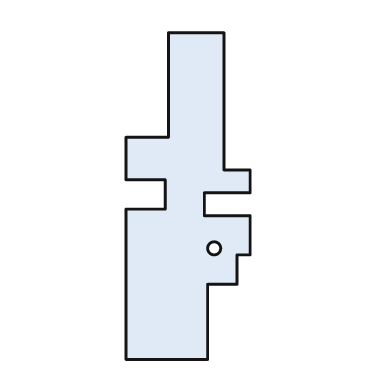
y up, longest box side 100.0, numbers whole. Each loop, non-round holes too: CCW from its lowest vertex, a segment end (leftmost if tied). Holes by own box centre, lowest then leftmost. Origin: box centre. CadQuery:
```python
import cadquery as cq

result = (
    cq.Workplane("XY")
    .moveTo(-19.0, -50.0)
    .lineTo(6.0, -50.0)
    .lineTo(6.0, -27.0)
    .lineTo(15.0, -27.0)
    .lineTo(15.0, -18.0)
    .lineTo(19.0, -18.0)
    .lineTo(19.0, -6.0)
    .lineTo(5.0, -6.0)
    .lineTo(5.0, 1.0)
    .lineTo(19.0, 1.0)
    .lineTo(19.0, 8.0)
    .lineTo(11.0, 8.0)
    .lineTo(11.0, 50.0)
    .lineTo(-6.0, 50.0)
    .lineTo(-6.0, 18.0)
    .lineTo(-19.0, 18.0)
    .lineTo(-19.0, 5.0)
    .lineTo(-7.0, 5.0)
    .lineTo(-7.0, -4.0)
    .lineTo(-19.0, -4.0)
    .close()
    .moveTo(8.0, -16.0)
    .circle(2.0)
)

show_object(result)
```